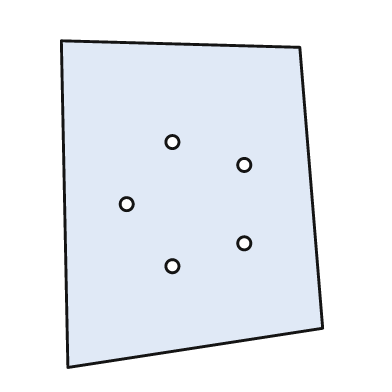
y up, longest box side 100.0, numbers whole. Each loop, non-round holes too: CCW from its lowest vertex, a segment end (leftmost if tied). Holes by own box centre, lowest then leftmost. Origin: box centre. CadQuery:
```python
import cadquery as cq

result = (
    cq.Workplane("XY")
    .moveTo(-38.0, -50.0)
    .lineTo(40.0, -38.0)
    .lineTo(33.0, 48.0)
    .lineTo(-40.0, 50.0)
    .close()
    .moveTo(-6.0, -19.0)
    .circle(2.0)
    .moveTo(16.0, -12.0)
    .circle(2.0)
    .moveTo(-20.0, 0.0)
    .circle(2.0)
    .moveTo(16.0, 12.0)
    .circle(2.0)
    .moveTo(-6.0, 19.0)
    .circle(2.0)
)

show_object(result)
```